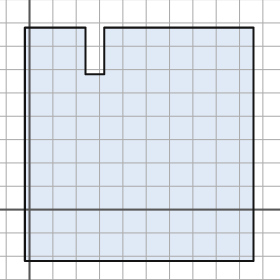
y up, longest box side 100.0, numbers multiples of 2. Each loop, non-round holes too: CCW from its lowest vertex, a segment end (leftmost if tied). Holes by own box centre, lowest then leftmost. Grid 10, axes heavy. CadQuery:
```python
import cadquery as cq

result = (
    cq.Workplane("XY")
    .moveTo(-2.0, -22.0)
    .lineTo(96.0, -22.0)
    .lineTo(96.0, 78.0)
    .lineTo(32.0, 78.0)
    .lineTo(32.0, 58.0)
    .lineTo(24.0, 58.0)
    .lineTo(24.0, 78.0)
    .lineTo(-2.0, 78.0)
    .close()
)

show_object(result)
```